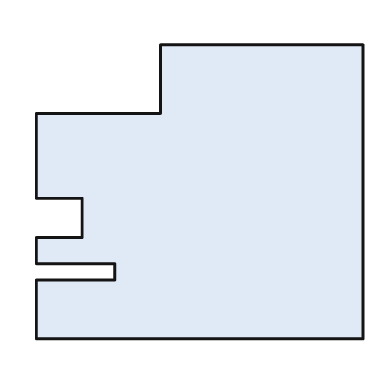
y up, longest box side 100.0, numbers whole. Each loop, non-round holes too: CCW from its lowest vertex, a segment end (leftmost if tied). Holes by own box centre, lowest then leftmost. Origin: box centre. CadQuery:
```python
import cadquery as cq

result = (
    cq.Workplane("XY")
    .moveTo(-50.0, -45.0)
    .lineTo(50.0, -45.0)
    .lineTo(50.0, 45.0)
    .lineTo(-12.0, 45.0)
    .lineTo(-12.0, 24.0)
    .lineTo(-50.0, 24.0)
    .lineTo(-50.0, -2.0)
    .lineTo(-36.0, -2.0)
    .lineTo(-36.0, -14.0)
    .lineTo(-50.0, -14.0)
    .lineTo(-50.0, -22.0)
    .lineTo(-26.0, -22.0)
    .lineTo(-26.0, -27.0)
    .lineTo(-50.0, -27.0)
    .close()
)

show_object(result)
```